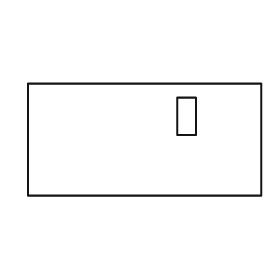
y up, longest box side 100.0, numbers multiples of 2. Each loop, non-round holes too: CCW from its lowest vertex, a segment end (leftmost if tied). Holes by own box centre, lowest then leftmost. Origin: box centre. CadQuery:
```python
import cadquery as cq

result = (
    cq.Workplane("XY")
    .moveTo(-50.0, -24.0)
    .lineTo(50.0, -24.0)
    .lineTo(50.0, 24.0)
    .lineTo(-50.0, 24.0)
    .close()
    .moveTo(14.0, 2.0)
    .lineTo(22.0, 2.0)
    .lineTo(22.0, 18.0)
    .lineTo(14.0, 18.0)
    .close()
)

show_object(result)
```